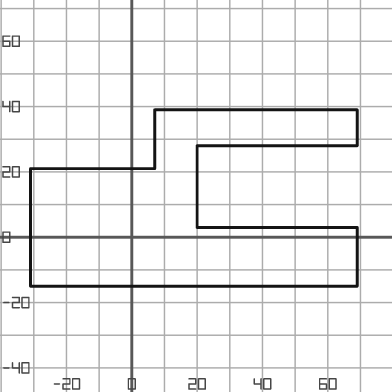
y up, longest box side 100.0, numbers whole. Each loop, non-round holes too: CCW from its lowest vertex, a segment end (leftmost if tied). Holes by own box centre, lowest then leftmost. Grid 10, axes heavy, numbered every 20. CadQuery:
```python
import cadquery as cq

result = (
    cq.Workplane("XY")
    .moveTo(-31.0, -15.0)
    .lineTo(69.0, -15.0)
    .lineTo(69.0, 3.0)
    .lineTo(20.0, 3.0)
    .lineTo(20.0, 28.0)
    .lineTo(69.0, 28.0)
    .lineTo(69.0, 39.0)
    .lineTo(7.0, 39.0)
    .lineTo(7.0, 21.0)
    .lineTo(-31.0, 21.0)
    .close()
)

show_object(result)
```